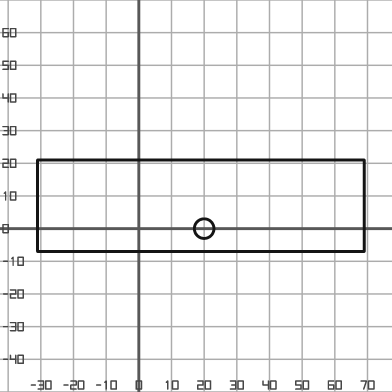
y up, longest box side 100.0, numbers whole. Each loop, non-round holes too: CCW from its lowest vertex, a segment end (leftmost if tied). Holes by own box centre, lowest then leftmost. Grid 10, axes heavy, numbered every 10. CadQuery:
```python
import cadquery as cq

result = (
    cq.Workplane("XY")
    .moveTo(-31.0, -7.0)
    .lineTo(69.0, -7.0)
    .lineTo(69.0, 21.0)
    .lineTo(-31.0, 21.0)
    .close()
    .moveTo(20.0, 0.0)
    .circle(3.0)
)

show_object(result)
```